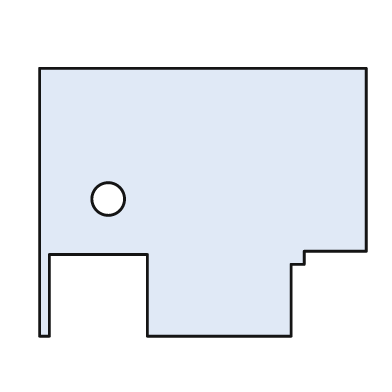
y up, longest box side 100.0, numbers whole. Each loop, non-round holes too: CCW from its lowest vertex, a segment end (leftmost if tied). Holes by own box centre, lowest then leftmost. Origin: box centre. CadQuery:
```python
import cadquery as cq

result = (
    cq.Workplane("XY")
    .moveTo(-50.0, -41.0)
    .lineTo(-47.0, -41.0)
    .lineTo(-47.0, -16.0)
    .lineTo(-17.0, -16.0)
    .lineTo(-17.0, -41.0)
    .lineTo(27.0, -41.0)
    .lineTo(27.0, -19.0)
    .lineTo(31.0, -19.0)
    .lineTo(31.0, -15.0)
    .lineTo(50.0, -15.0)
    .lineTo(50.0, 41.0)
    .lineTo(-50.0, 41.0)
    .close()
    .moveTo(-29.0, 1.0)
    .circle(5.0)
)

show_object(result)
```